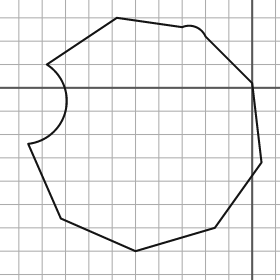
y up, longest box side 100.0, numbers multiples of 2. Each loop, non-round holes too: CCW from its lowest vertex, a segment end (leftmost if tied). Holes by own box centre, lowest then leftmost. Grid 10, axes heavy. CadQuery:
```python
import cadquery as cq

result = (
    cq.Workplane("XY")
    .moveTo(-50.0, -70.0)
    .lineTo(-16.0, -60.0)
    .lineTo(4.0, -32.0)
    .lineTo(0.0, 2.0)
    .lineTo(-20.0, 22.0)
    .threePointArc((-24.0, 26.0), (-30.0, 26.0))
    .lineTo(-58.0, 30.0)
    .lineTo(-88.0, 10.0)
    .threePointArc((-80.0, -10.0), (-96.0, -24.0))
    .lineTo(-82.0, -56.0)
    .close()
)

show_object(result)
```